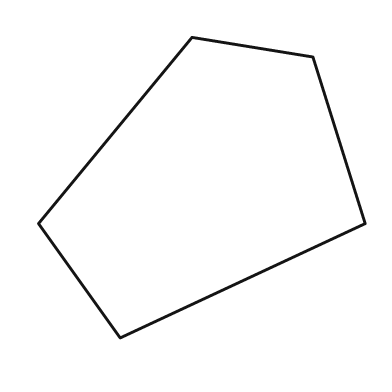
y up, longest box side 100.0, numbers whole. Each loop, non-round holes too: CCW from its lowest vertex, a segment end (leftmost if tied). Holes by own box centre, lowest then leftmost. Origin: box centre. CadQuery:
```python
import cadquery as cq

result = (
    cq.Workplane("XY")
    .moveTo(-25.0, -46.0)
    .lineTo(50.0, -11.0)
    .lineTo(34.0, 40.0)
    .lineTo(-3.0, 46.0)
    .lineTo(-50.0, -11.0)
    .close()
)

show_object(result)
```